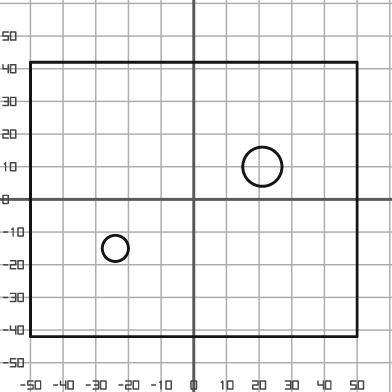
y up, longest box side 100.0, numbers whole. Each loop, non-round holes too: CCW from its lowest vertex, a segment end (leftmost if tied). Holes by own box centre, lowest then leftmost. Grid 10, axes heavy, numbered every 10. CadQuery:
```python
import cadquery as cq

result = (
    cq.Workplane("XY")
    .moveTo(-50.0, -42.0)
    .lineTo(50.0, -42.0)
    .lineTo(50.0, 42.0)
    .lineTo(-50.0, 42.0)
    .close()
    .moveTo(-24.0, -15.0)
    .circle(4.0)
    .moveTo(21.0, 10.0)
    .circle(6.0)
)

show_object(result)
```